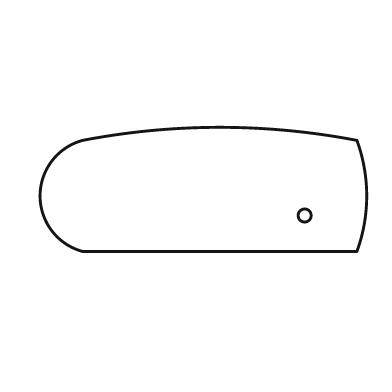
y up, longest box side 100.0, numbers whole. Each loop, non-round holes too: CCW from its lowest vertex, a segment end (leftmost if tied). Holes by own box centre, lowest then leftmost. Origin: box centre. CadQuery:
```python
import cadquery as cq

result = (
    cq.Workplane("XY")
    .moveTo(-37.0, -19.0)
    .lineTo(47.0, -19.0)
    .threePointArc((50.0, -2.0), (47.0, 15.0))
    .threePointArc((5.0, 19.0), (-37.0, 15.0))
    .threePointArc((-50.0, -2.0), (-37.0, -19.0))
    .close()
    .moveTo(31.0, -8.0)
    .circle(2.0)
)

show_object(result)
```